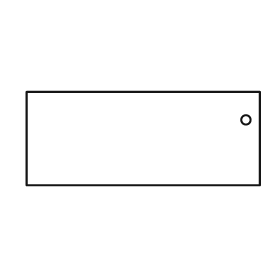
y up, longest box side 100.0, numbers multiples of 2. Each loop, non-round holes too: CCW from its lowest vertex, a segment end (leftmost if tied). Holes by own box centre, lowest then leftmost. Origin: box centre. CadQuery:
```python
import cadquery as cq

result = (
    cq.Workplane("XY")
    .moveTo(-50.0, -20.0)
    .lineTo(50.0, -20.0)
    .lineTo(50.0, 20.0)
    .lineTo(-50.0, 20.0)
    .close()
    .moveTo(44.0, 8.0)
    .circle(2.0)
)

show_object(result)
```